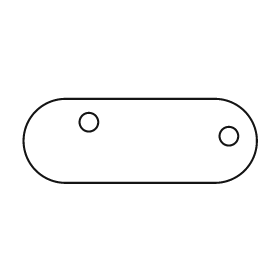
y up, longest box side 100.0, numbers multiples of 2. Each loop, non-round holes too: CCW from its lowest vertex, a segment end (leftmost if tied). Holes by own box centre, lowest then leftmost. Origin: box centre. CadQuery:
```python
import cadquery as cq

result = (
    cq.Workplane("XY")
    .moveTo(-32.0, -18.0)
    .lineTo(32.0, -18.0)
    .threePointArc((50.0, 0.0), (32.0, 18.0))
    .lineTo(-32.0, 18.0)
    .threePointArc((-50.0, 0.0), (-32.0, -18.0))
    .close()
    .moveTo(38.0, 2.0)
    .circle(4.0)
    .moveTo(-22.0, 8.0)
    .circle(4.0)
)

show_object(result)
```